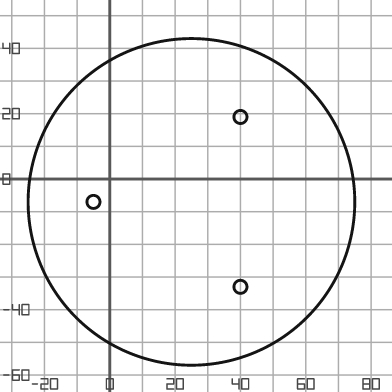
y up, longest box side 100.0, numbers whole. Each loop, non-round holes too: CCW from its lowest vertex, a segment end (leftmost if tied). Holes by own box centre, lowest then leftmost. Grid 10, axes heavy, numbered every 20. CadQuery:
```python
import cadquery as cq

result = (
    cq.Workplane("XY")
    .moveTo(25.0, -7.0)
    .circle(50.0)
    .moveTo(40.0, -33.0)
    .circle(2.0)
    .moveTo(-5.0, -7.0)
    .circle(2.0)
    .moveTo(40.0, 19.0)
    .circle(2.0)
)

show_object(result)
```